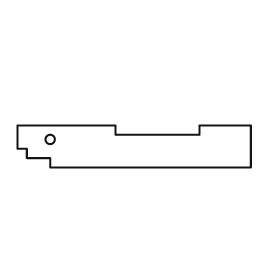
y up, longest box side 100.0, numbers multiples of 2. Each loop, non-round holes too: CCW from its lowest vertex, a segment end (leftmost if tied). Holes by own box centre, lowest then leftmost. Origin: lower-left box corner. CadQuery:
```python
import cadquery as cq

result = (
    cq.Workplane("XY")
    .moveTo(14.0, 0.0)
    .lineTo(100.0, 0.0)
    .lineTo(100.0, 18.0)
    .lineTo(78.0, 18.0)
    .lineTo(78.0, 14.0)
    .lineTo(42.0, 14.0)
    .lineTo(42.0, 18.0)
    .lineTo(0.0, 18.0)
    .lineTo(0.0, 8.0)
    .lineTo(4.0, 8.0)
    .lineTo(4.0, 4.0)
    .lineTo(14.0, 4.0)
    .close()
    .moveTo(14.0, 12.0)
    .circle(2.0)
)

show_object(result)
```